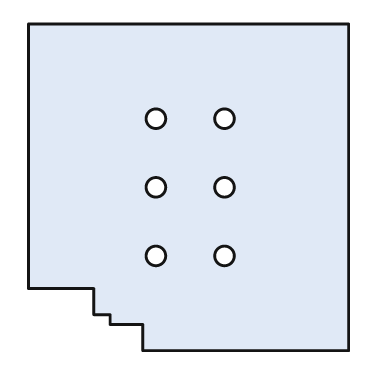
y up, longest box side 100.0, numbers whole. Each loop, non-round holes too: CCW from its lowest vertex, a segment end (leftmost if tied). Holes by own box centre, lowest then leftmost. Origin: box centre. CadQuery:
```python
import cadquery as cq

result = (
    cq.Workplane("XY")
    .moveTo(-14.0, -50.0)
    .lineTo(49.0, -50.0)
    .lineTo(49.0, 50.0)
    .lineTo(-49.0, 50.0)
    .lineTo(-49.0, -31.0)
    .lineTo(-29.0, -31.0)
    .lineTo(-29.0, -39.0)
    .lineTo(-24.0, -39.0)
    .lineTo(-24.0, -42.0)
    .lineTo(-14.0, -42.0)
    .close()
    .moveTo(-10.0, -21.0)
    .circle(3.0)
    .moveTo(11.0, -21.0)
    .circle(3.0)
    .moveTo(-10.0, 0.0)
    .circle(3.0)
    .moveTo(11.0, 0.0)
    .circle(3.0)
    .moveTo(-10.0, 21.0)
    .circle(3.0)
    .moveTo(11.0, 21.0)
    .circle(3.0)
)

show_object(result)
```